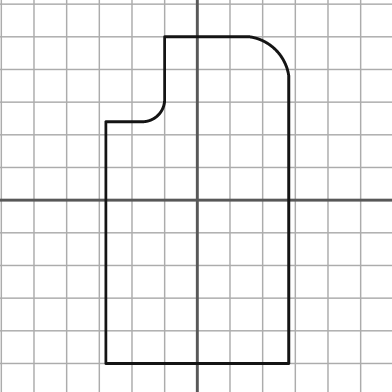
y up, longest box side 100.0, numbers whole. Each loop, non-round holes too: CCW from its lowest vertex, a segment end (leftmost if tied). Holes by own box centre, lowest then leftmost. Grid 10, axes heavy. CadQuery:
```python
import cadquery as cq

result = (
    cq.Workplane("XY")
    .moveTo(-28.0, -50.0)
    .lineTo(28.0, -50.0)
    .lineTo(28.0, 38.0)
    .threePointArc((24.0, 46.0), (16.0, 50.0))
    .lineTo(-10.0, 50.0)
    .lineTo(-10.0, 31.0)
    .threePointArc((-12.0, 26.0), (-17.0, 24.0))
    .lineTo(-28.0, 24.0)
    .close()
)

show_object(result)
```